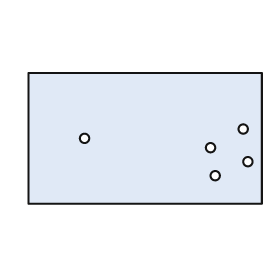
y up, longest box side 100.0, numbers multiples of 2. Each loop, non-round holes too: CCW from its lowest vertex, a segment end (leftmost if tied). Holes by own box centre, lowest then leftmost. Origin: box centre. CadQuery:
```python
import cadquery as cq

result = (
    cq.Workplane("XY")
    .moveTo(-50.0, -28.0)
    .lineTo(50.0, -28.0)
    .lineTo(50.0, 28.0)
    .lineTo(-50.0, 28.0)
    .close()
    .moveTo(30.0, -16.0)
    .circle(2.0)
    .moveTo(44.0, -10.0)
    .circle(2.0)
    .moveTo(28.0, -4.0)
    .circle(2.0)
    .moveTo(-26.0, 0.0)
    .circle(2.0)
    .moveTo(42.0, 4.0)
    .circle(2.0)
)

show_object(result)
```